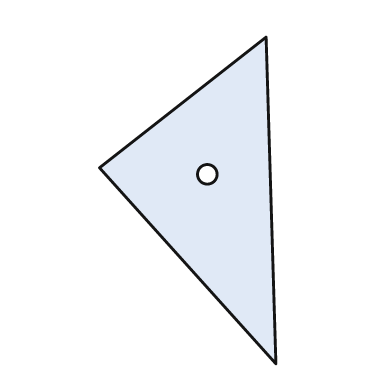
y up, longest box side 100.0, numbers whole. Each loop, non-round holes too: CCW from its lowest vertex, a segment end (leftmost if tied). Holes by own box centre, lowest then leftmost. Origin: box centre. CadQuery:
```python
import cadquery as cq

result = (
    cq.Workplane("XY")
    .moveTo(27.0, -50.0)
    .lineTo(24.0, 50.0)
    .lineTo(-27.0, 10.0)
    .close()
    .moveTo(6.0, 8.0)
    .circle(3.0)
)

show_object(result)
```